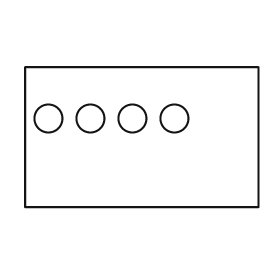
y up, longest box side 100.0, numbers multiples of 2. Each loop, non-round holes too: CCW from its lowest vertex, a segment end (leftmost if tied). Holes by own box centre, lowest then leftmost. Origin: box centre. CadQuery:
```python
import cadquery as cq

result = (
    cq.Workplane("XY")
    .moveTo(-50.0, -30.0)
    .lineTo(50.0, -30.0)
    .lineTo(50.0, 30.0)
    .lineTo(-50.0, 30.0)
    .close()
    .moveTo(-40.0, 8.0)
    .circle(6.0)
    .moveTo(-22.0, 8.0)
    .circle(6.0)
    .moveTo(-4.0, 8.0)
    .circle(6.0)
    .moveTo(14.0, 8.0)
    .circle(6.0)
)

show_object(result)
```